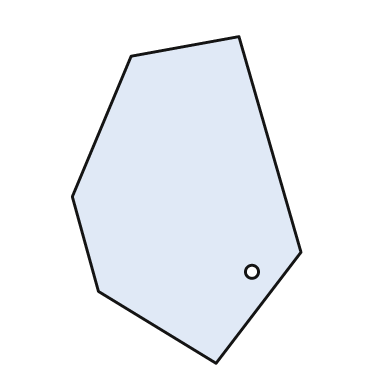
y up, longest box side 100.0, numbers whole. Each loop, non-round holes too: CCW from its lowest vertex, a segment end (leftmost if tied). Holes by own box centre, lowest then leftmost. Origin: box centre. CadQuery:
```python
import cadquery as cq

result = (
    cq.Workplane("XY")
    .moveTo(9.0, -50.0)
    .lineTo(35.0, -16.0)
    .lineTo(16.0, 50.0)
    .lineTo(-17.0, 44.0)
    .lineTo(-35.0, 1.0)
    .lineTo(-27.0, -28.0)
    .close()
    .moveTo(20.0, -22.0)
    .circle(2.0)
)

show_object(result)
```